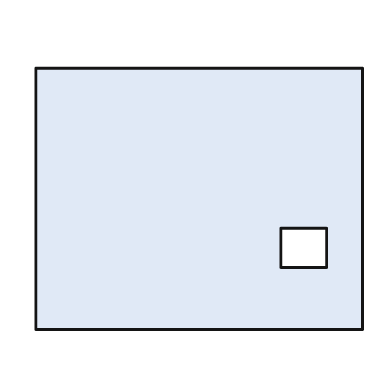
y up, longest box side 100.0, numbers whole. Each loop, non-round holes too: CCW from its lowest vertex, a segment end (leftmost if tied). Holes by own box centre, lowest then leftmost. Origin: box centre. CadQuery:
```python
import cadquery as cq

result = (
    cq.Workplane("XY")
    .moveTo(-50.0, -40.0)
    .lineTo(50.0, -40.0)
    .lineTo(50.0, 40.0)
    .lineTo(-50.0, 40.0)
    .close()
    .moveTo(25.0, -21.0)
    .lineTo(39.0, -21.0)
    .lineTo(39.0, -9.0)
    .lineTo(25.0, -9.0)
    .close()
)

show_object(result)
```